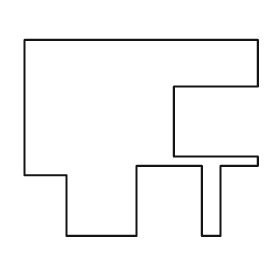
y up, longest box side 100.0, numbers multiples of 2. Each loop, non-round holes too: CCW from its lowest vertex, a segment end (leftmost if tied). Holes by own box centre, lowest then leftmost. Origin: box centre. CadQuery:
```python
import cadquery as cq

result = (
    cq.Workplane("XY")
    .moveTo(-32.0, -42.0)
    .lineTo(-2.0, -42.0)
    .lineTo(-2.0, -12.0)
    .lineTo(26.0, -12.0)
    .lineTo(26.0, -42.0)
    .lineTo(34.0, -42.0)
    .lineTo(34.0, -12.0)
    .lineTo(50.0, -12.0)
    .lineTo(50.0, -8.0)
    .lineTo(14.0, -8.0)
    .lineTo(14.0, 22.0)
    .lineTo(50.0, 22.0)
    .lineTo(50.0, 42.0)
    .lineTo(-50.0, 42.0)
    .lineTo(-50.0, -16.0)
    .lineTo(-32.0, -16.0)
    .close()
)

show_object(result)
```